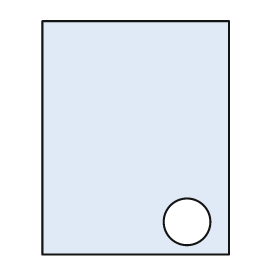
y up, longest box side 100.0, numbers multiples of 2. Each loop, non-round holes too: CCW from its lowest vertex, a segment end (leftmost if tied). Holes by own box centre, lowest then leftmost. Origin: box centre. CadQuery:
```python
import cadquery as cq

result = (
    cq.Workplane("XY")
    .moveTo(-40.0, -50.0)
    .lineTo(40.0, -50.0)
    .lineTo(40.0, 50.0)
    .lineTo(-40.0, 50.0)
    .close()
    .moveTo(22.0, -36.0)
    .circle(10.0)
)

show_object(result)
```